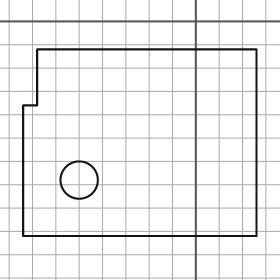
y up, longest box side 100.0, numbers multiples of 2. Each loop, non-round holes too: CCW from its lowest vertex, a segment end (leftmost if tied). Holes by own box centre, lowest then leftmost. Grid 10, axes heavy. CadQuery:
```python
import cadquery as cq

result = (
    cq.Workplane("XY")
    .moveTo(-74.0, -92.0)
    .lineTo(26.0, -92.0)
    .lineTo(26.0, -12.0)
    .lineTo(-68.0, -12.0)
    .lineTo(-68.0, -36.0)
    .lineTo(-74.0, -36.0)
    .close()
    .moveTo(-50.0, -68.0)
    .circle(8.0)
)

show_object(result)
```